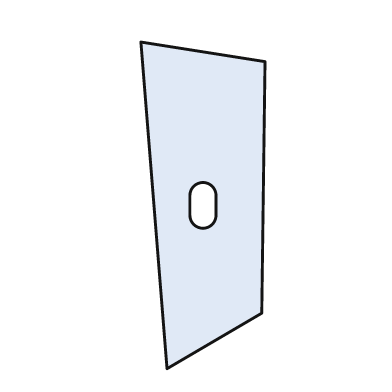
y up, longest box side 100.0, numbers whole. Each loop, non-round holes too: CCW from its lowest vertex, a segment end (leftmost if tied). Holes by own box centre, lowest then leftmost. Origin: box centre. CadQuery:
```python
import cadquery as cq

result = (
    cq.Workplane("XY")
    .moveTo(-11.0, -50.0)
    .lineTo(18.0, -33.0)
    .lineTo(19.0, 44.0)
    .lineTo(-19.0, 50.0)
    .close()
    .moveTo(-4.0, -3.0)
    .threePointArc((0.0, -7.0), (4.0, -3.0))
    .lineTo(4.0, 3.0)
    .threePointArc((0.0, 7.0), (-4.0, 3.0))
    .close()
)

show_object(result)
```